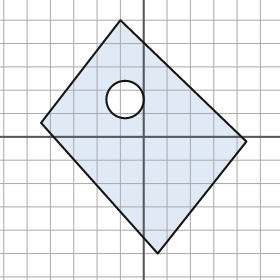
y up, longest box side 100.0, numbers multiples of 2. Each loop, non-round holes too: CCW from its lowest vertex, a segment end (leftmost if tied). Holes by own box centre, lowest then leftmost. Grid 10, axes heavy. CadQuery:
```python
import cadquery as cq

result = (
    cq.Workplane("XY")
    .moveTo(6.0, -50.0)
    .lineTo(44.0, -2.0)
    .lineTo(-10.0, 50.0)
    .lineTo(-44.0, 6.0)
    .close()
    .moveTo(-8.0, 16.0)
    .circle(8.0)
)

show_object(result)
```